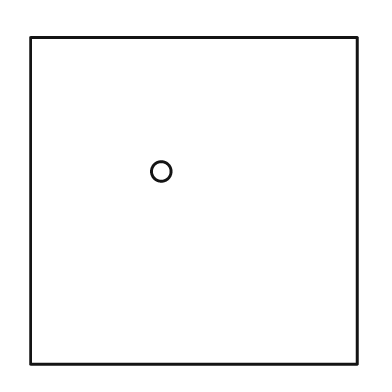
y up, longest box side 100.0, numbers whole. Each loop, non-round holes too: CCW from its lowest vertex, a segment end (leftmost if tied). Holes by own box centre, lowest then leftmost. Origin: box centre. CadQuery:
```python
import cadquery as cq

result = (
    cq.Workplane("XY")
    .moveTo(-50.0, -50.0)
    .lineTo(50.0, -50.0)
    .lineTo(50.0, 50.0)
    .lineTo(-50.0, 50.0)
    .close()
    .moveTo(-10.0, 9.0)
    .circle(3.0)
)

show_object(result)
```